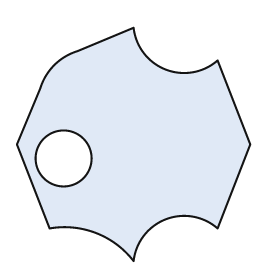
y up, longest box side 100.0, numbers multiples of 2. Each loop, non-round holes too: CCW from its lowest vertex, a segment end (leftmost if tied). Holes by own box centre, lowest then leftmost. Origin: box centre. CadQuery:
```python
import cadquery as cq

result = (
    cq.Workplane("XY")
    .moveTo(0.0, -50.0)
    .threePointArc((14.0, -32.0), (36.0, -36.0))
    .lineTo(50.0, 0.0)
    .lineTo(36.0, 36.0)
    .threePointArc((14.0, 32.0), (0.0, 50.0))
    .lineTo(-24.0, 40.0)
    .threePointArc((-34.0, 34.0), (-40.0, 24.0))
    .lineTo(-50.0, 0.0)
    .lineTo(-36.0, -36.0)
    .threePointArc((-16.0, -38.0), (0.0, -50.0))
    .close()
    .moveTo(-30.0, -6.0)
    .circle(12.0)
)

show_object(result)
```